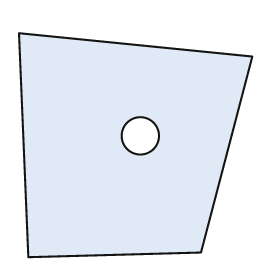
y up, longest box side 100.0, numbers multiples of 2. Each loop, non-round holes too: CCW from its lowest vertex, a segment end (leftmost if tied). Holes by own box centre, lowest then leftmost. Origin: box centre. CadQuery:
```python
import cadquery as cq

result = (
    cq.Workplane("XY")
    .moveTo(-46.0, -48.0)
    .lineTo(28.0, -46.0)
    .lineTo(50.0, 38.0)
    .lineTo(-50.0, 48.0)
    .close()
    .moveTo(2.0, 4.0)
    .circle(8.0)
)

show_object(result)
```